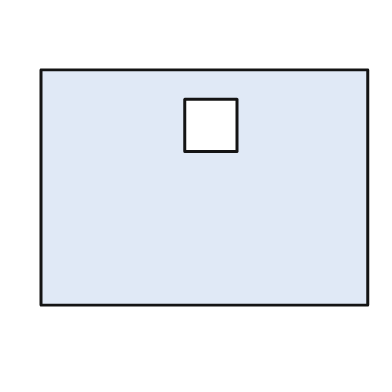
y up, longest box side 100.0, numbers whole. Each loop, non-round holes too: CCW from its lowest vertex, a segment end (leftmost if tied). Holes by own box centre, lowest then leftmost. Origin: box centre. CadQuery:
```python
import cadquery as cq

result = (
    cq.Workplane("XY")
    .moveTo(-50.0, -36.0)
    .lineTo(50.0, -36.0)
    .lineTo(50.0, 36.0)
    .lineTo(-50.0, 36.0)
    .close()
    .moveTo(-6.0, 11.0)
    .lineTo(10.0, 11.0)
    .lineTo(10.0, 27.0)
    .lineTo(-6.0, 27.0)
    .close()
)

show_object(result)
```